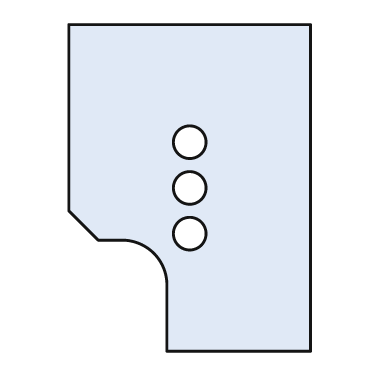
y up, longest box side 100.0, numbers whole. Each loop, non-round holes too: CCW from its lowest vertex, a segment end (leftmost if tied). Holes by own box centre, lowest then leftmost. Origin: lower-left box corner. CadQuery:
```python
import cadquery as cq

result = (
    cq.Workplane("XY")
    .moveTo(30.0, 0.0)
    .lineTo(74.0, 0.0)
    .lineTo(74.0, 100.0)
    .lineTo(0.0, 100.0)
    .lineTo(0.0, 43.0)
    .lineTo(9.0, 34.0)
    .lineTo(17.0, 34.0)
    .threePointArc((26.0, 30.0), (30.0, 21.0))
    .close()
    .moveTo(37.0, 36.0)
    .circle(5.0)
    .moveTo(37.0, 50.0)
    .circle(5.0)
    .moveTo(37.0, 64.0)
    .circle(5.0)
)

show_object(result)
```